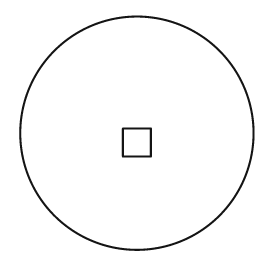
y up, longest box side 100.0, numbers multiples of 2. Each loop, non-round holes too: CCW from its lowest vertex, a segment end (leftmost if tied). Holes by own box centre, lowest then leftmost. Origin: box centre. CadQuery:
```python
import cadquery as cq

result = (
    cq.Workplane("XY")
    .moveTo(0.0, 0.0)
    .circle(50.0)
    .moveTo(-6.0, -10.0)
    .lineTo(6.0, -10.0)
    .lineTo(6.0, 2.0)
    .lineTo(-6.0, 2.0)
    .close()
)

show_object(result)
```